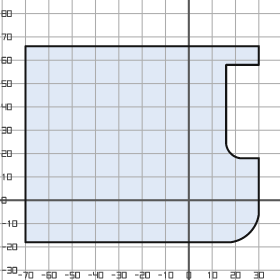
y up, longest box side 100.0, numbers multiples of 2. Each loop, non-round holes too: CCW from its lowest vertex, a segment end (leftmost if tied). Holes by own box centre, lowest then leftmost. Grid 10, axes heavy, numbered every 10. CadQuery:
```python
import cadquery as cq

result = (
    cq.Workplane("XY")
    .moveTo(-70.0, -18.0)
    .lineTo(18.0, -18.0)
    .threePointArc((26.0, -14.0), (30.0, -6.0))
    .lineTo(30.0, 18.0)
    .lineTo(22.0, 18.0)
    .threePointArc((18.0, 20.0), (16.0, 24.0))
    .lineTo(16.0, 58.0)
    .lineTo(30.0, 58.0)
    .lineTo(30.0, 66.0)
    .lineTo(-70.0, 66.0)
    .close()
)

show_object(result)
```